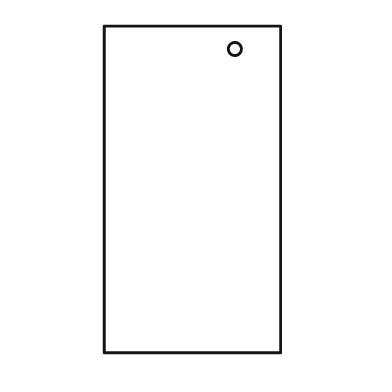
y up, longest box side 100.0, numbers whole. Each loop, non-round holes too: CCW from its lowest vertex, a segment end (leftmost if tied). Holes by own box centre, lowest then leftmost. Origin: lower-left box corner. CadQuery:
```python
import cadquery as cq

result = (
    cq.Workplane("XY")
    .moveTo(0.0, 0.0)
    .lineTo(54.0, 0.0)
    .lineTo(54.0, 100.0)
    .lineTo(0.0, 100.0)
    .close()
    .moveTo(40.0, 93.0)
    .circle(2.0)
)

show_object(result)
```